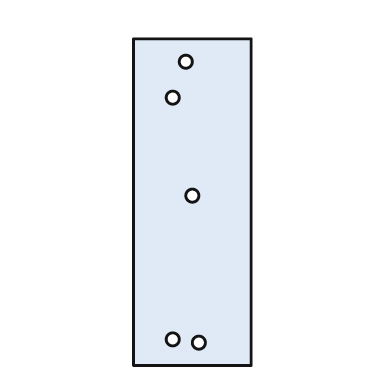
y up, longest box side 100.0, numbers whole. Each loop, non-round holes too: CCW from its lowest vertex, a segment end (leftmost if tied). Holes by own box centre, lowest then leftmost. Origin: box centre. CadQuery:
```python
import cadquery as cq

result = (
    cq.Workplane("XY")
    .moveTo(-18.0, -50.0)
    .lineTo(18.0, -50.0)
    .lineTo(18.0, 50.0)
    .lineTo(-18.0, 50.0)
    .close()
    .moveTo(2.0, -43.0)
    .circle(2.0)
    .moveTo(-6.0, -42.0)
    .circle(2.0)
    .moveTo(0.0, 2.0)
    .circle(2.0)
    .moveTo(-6.0, 32.0)
    .circle(2.0)
    .moveTo(-2.0, 43.0)
    .circle(2.0)
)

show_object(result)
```